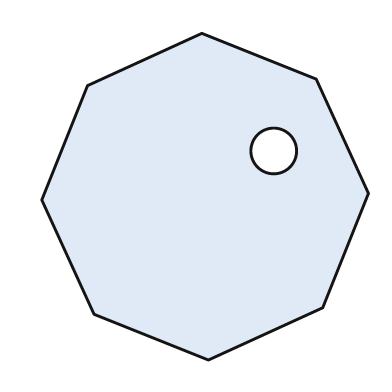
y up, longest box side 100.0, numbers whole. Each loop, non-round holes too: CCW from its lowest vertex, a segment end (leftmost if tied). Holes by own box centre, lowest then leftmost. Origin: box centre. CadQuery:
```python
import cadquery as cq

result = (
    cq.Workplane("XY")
    .moveTo(1.0, -50.0)
    .lineTo(36.0, -34.0)
    .lineTo(50.0, 1.0)
    .lineTo(34.0, 36.0)
    .lineTo(-1.0, 50.0)
    .lineTo(-36.0, 34.0)
    .lineTo(-50.0, -1.0)
    .lineTo(-34.0, -36.0)
    .close()
    .moveTo(21.0, 14.0)
    .circle(7.0)
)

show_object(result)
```